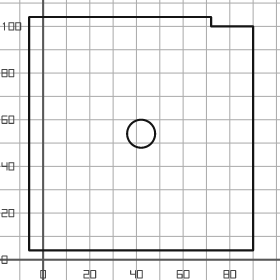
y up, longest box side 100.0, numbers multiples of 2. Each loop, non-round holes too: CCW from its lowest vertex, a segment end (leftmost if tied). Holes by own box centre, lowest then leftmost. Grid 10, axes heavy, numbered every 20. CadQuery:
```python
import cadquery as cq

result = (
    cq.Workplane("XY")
    .moveTo(-6.0, 4.0)
    .lineTo(90.0, 4.0)
    .lineTo(90.0, 100.0)
    .lineTo(72.0, 100.0)
    .lineTo(72.0, 104.0)
    .lineTo(-6.0, 104.0)
    .close()
    .moveTo(42.0, 54.0)
    .circle(6.0)
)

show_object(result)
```